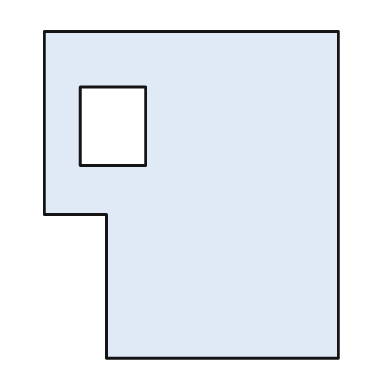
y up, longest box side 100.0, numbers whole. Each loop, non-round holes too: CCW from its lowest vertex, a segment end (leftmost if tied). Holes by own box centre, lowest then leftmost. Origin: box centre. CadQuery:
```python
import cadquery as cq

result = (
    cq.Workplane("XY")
    .moveTo(-26.0, -50.0)
    .lineTo(45.0, -50.0)
    .lineTo(45.0, 50.0)
    .lineTo(-45.0, 50.0)
    .lineTo(-45.0, -6.0)
    .lineTo(-26.0, -6.0)
    .close()
    .moveTo(-34.0, 9.0)
    .lineTo(-14.0, 9.0)
    .lineTo(-14.0, 33.0)
    .lineTo(-34.0, 33.0)
    .close()
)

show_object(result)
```